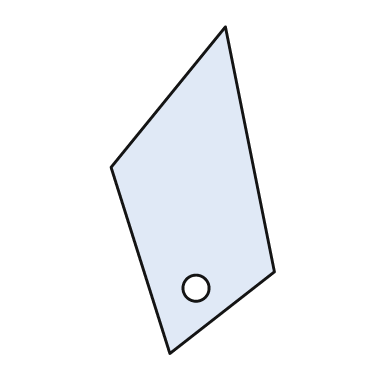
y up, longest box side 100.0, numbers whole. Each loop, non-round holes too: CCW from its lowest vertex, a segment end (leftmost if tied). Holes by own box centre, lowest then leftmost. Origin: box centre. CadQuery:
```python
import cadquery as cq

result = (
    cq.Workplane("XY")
    .moveTo(-7.0, -50.0)
    .lineTo(25.0, -25.0)
    .lineTo(10.0, 50.0)
    .lineTo(-25.0, 7.0)
    .close()
    .moveTo(1.0, -30.0)
    .circle(4.0)
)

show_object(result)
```